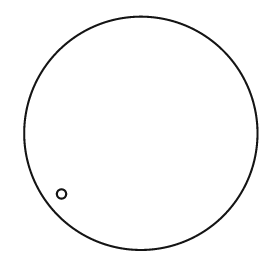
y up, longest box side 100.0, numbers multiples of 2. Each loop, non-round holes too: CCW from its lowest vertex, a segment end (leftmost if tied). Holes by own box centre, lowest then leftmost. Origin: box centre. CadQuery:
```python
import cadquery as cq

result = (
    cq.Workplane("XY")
    .moveTo(0.0, 0.0)
    .circle(50.0)
    .moveTo(-34.0, -26.0)
    .circle(2.0)
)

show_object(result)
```